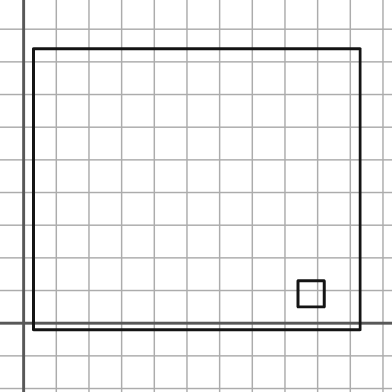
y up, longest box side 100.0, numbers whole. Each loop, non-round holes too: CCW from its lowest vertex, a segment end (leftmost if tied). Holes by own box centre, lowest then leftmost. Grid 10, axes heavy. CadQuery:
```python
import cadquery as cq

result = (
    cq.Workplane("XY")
    .moveTo(3.0, -2.0)
    .lineTo(103.0, -2.0)
    .lineTo(103.0, 84.0)
    .lineTo(3.0, 84.0)
    .close()
    .moveTo(84.0, 5.0)
    .lineTo(92.0, 5.0)
    .lineTo(92.0, 13.0)
    .lineTo(84.0, 13.0)
    .close()
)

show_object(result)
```